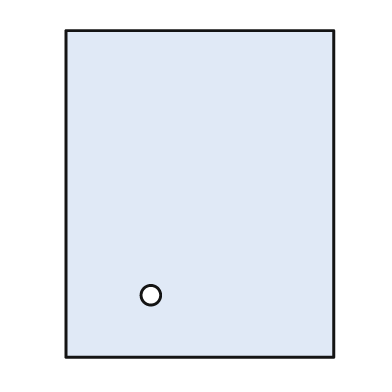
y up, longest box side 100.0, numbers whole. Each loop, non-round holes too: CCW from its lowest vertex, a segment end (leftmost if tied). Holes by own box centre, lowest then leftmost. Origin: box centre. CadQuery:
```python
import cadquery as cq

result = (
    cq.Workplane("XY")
    .moveTo(-41.0, -50.0)
    .lineTo(41.0, -50.0)
    .lineTo(41.0, 50.0)
    .lineTo(-41.0, 50.0)
    .close()
    .moveTo(-15.0, -31.0)
    .circle(3.0)
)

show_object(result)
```